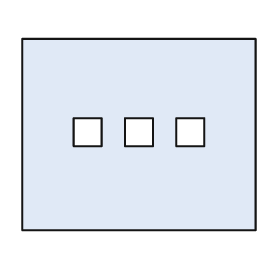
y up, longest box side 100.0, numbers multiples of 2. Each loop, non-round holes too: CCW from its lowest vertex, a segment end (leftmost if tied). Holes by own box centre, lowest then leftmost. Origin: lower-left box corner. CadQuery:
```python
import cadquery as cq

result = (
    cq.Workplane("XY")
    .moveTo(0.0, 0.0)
    .lineTo(100.0, 0.0)
    .lineTo(100.0, 82.0)
    .lineTo(0.0, 82.0)
    .close()
    .moveTo(22.0, 36.0)
    .lineTo(34.0, 36.0)
    .lineTo(34.0, 48.0)
    .lineTo(22.0, 48.0)
    .close()
    .moveTo(44.0, 36.0)
    .lineTo(56.0, 36.0)
    .lineTo(56.0, 48.0)
    .lineTo(44.0, 48.0)
    .close()
    .moveTo(66.0, 36.0)
    .lineTo(78.0, 36.0)
    .lineTo(78.0, 48.0)
    .lineTo(66.0, 48.0)
    .close()
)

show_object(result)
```